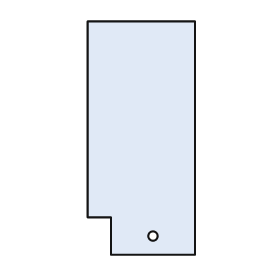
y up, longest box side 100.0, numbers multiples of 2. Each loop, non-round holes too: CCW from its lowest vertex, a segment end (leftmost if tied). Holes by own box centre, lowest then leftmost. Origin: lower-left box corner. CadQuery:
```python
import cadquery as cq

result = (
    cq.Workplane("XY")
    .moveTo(10.0, 0.0)
    .lineTo(46.0, 0.0)
    .lineTo(46.0, 100.0)
    .lineTo(0.0, 100.0)
    .lineTo(0.0, 16.0)
    .lineTo(10.0, 16.0)
    .close()
    .moveTo(28.0, 8.0)
    .circle(2.0)
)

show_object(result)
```